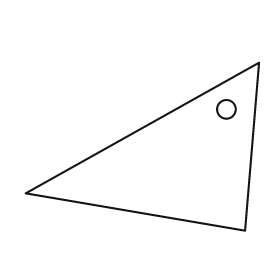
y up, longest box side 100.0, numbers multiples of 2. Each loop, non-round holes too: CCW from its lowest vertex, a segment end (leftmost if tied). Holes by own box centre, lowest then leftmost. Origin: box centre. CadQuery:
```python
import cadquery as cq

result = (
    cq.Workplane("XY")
    .moveTo(44.0, -36.0)
    .lineTo(50.0, 36.0)
    .lineTo(-50.0, -20.0)
    .close()
    .moveTo(36.0, 16.0)
    .circle(4.0)
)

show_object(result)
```